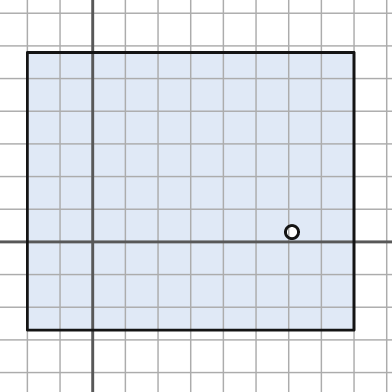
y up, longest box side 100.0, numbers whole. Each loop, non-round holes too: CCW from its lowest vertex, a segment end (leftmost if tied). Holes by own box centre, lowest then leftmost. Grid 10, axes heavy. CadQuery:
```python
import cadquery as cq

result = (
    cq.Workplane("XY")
    .moveTo(-20.0, -27.0)
    .lineTo(80.0, -27.0)
    .lineTo(80.0, 58.0)
    .lineTo(-20.0, 58.0)
    .close()
    .moveTo(61.0, 3.0)
    .circle(2.0)
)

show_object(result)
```